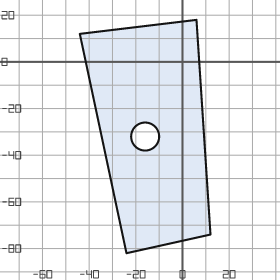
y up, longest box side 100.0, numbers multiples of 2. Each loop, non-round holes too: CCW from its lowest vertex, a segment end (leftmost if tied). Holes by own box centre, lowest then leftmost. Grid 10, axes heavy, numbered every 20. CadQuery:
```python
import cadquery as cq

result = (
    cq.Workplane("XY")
    .moveTo(-24.0, -82.0)
    .lineTo(12.0, -74.0)
    .lineTo(6.0, 18.0)
    .lineTo(-44.0, 12.0)
    .close()
    .moveTo(-16.0, -32.0)
    .circle(6.0)
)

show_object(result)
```